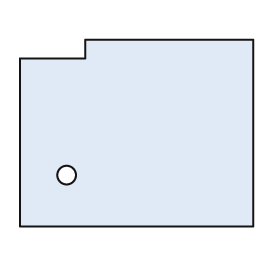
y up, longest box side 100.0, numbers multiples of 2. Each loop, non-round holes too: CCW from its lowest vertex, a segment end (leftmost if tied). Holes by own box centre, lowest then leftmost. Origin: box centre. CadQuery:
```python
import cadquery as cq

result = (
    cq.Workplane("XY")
    .moveTo(-50.0, -40.0)
    .lineTo(50.0, -40.0)
    .lineTo(50.0, 40.0)
    .lineTo(-22.0, 40.0)
    .lineTo(-22.0, 32.0)
    .lineTo(-50.0, 32.0)
    .close()
    .moveTo(-30.0, -18.0)
    .circle(4.0)
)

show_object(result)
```